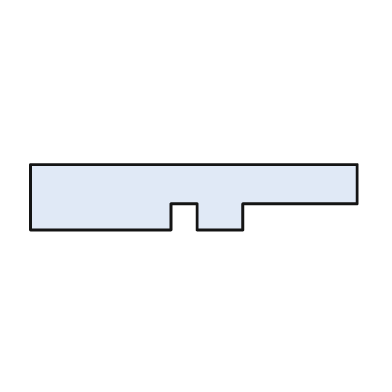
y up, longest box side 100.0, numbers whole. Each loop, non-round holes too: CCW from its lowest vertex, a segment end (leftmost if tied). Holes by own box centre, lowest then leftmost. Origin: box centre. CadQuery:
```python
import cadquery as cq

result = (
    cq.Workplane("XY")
    .moveTo(-50.0, -10.0)
    .lineTo(-7.0, -10.0)
    .lineTo(-7.0, -2.0)
    .lineTo(1.0, -2.0)
    .lineTo(1.0, -10.0)
    .lineTo(15.0, -10.0)
    .lineTo(15.0, -2.0)
    .lineTo(50.0, -2.0)
    .lineTo(50.0, 10.0)
    .lineTo(-50.0, 10.0)
    .close()
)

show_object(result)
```